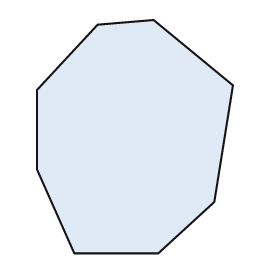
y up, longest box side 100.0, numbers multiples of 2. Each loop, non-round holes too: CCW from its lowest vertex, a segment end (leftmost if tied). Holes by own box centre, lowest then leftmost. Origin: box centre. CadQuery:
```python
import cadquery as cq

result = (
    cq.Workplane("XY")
    .moveTo(-26.0, -50.0)
    .lineTo(10.0, -50.0)
    .lineTo(34.0, -28.0)
    .lineTo(42.0, 22.0)
    .lineTo(8.0, 50.0)
    .lineTo(-16.0, 48.0)
    .lineTo(-42.0, 20.0)
    .lineTo(-42.0, -14.0)
    .close()
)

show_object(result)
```